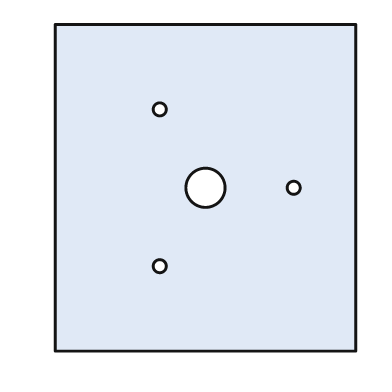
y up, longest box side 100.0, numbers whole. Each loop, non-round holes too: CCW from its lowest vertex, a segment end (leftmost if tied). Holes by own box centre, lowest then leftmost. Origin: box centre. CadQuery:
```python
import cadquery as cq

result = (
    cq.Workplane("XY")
    .moveTo(-46.0, -50.0)
    .lineTo(46.0, -50.0)
    .lineTo(46.0, 50.0)
    .lineTo(-46.0, 50.0)
    .close()
    .moveTo(-14.0, -24.0)
    .circle(2.0)
    .moveTo(0.0, 0.0)
    .circle(6.0)
    .moveTo(27.0, 0.0)
    .circle(2.0)
    .moveTo(-14.0, 24.0)
    .circle(2.0)
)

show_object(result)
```